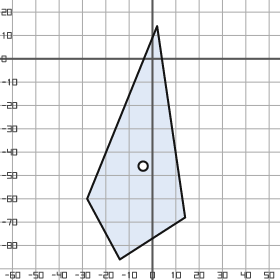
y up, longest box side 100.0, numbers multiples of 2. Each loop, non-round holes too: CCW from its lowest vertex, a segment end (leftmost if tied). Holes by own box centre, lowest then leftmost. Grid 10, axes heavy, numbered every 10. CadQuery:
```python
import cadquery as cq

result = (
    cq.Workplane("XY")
    .moveTo(-14.0, -86.0)
    .lineTo(14.0, -68.0)
    .lineTo(2.0, 14.0)
    .lineTo(-28.0, -60.0)
    .close()
    .moveTo(-4.0, -46.0)
    .circle(2.0)
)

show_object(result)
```